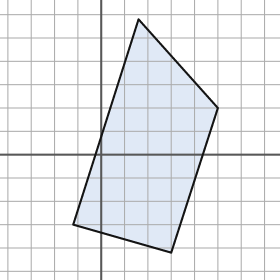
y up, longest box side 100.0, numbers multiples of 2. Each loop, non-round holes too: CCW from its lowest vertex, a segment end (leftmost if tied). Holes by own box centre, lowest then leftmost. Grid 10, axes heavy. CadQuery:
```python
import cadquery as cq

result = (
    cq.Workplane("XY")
    .moveTo(30.0, -42.0)
    .lineTo(50.0, 20.0)
    .lineTo(16.0, 58.0)
    .lineTo(-12.0, -30.0)
    .close()
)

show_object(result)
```